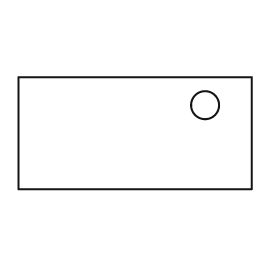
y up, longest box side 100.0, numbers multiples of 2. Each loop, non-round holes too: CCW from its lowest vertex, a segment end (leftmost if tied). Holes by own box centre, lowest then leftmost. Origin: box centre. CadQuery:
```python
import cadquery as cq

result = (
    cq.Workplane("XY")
    .moveTo(-50.0, -24.0)
    .lineTo(50.0, -24.0)
    .lineTo(50.0, 24.0)
    .lineTo(-50.0, 24.0)
    .close()
    .moveTo(30.0, 12.0)
    .circle(6.0)
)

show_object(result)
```